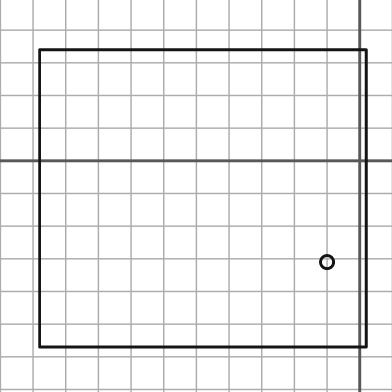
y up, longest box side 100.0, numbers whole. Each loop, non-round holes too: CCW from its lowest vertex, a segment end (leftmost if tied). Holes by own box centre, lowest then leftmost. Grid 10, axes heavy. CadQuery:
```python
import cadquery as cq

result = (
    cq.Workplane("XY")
    .moveTo(-98.0, -57.0)
    .lineTo(2.0, -57.0)
    .lineTo(2.0, 34.0)
    .lineTo(-98.0, 34.0)
    .close()
    .moveTo(-10.0, -31.0)
    .circle(2.0)
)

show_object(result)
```